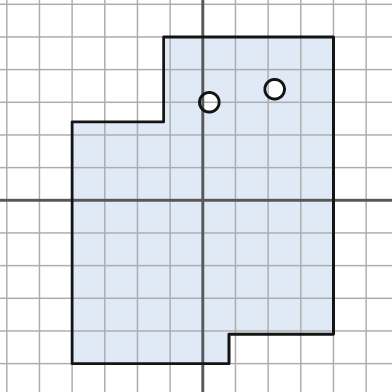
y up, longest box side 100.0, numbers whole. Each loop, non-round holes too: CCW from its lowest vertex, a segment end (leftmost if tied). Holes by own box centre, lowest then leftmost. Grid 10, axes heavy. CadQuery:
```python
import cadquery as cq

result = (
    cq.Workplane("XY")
    .moveTo(-40.0, -50.0)
    .lineTo(8.0, -50.0)
    .lineTo(8.0, -41.0)
    .lineTo(40.0, -41.0)
    .lineTo(40.0, 50.0)
    .lineTo(-12.0, 50.0)
    .lineTo(-12.0, 24.0)
    .lineTo(-40.0, 24.0)
    .close()
    .moveTo(2.0, 30.0)
    .circle(3.0)
    .moveTo(22.0, 34.0)
    .circle(3.0)
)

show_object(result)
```